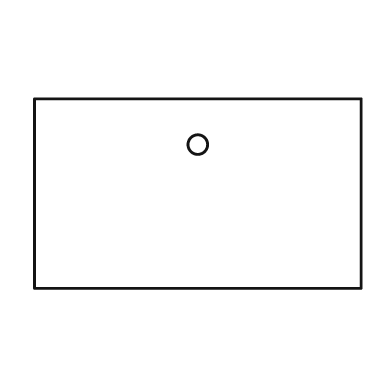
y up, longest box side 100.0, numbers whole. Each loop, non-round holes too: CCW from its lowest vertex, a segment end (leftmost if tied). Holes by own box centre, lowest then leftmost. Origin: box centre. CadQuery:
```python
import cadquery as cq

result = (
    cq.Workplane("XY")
    .moveTo(-50.0, -29.0)
    .lineTo(50.0, -29.0)
    .lineTo(50.0, 29.0)
    .lineTo(-50.0, 29.0)
    .close()
    .moveTo(0.0, 15.0)
    .circle(3.0)
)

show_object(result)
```